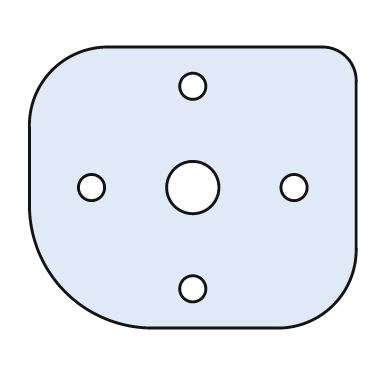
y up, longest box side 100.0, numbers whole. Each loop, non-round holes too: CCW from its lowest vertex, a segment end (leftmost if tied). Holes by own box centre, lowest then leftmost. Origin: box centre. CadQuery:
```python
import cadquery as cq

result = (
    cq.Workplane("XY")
    .moveTo(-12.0, -43.0)
    .lineTo(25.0, -43.0)
    .threePointArc((43.0, -36.0), (50.0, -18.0))
    .lineTo(50.0, 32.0)
    .threePointArc((47.0, 40.0), (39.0, 43.0))
    .lineTo(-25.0, 43.0)
    .threePointArc((-43.0, 36.0), (-50.0, 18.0))
    .lineTo(-50.0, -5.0)
    .threePointArc((-39.0, -32.0), (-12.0, -43.0))
    .close()
    .moveTo(0.0, -31.0)
    .circle(4.0)
    .moveTo(-31.0, 0.0)
    .circle(4.0)
    .moveTo(0.0, 0.0)
    .circle(8.0)
    .moveTo(31.0, 0.0)
    .circle(4.0)
    .moveTo(0.0, 31.0)
    .circle(4.0)
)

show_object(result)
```